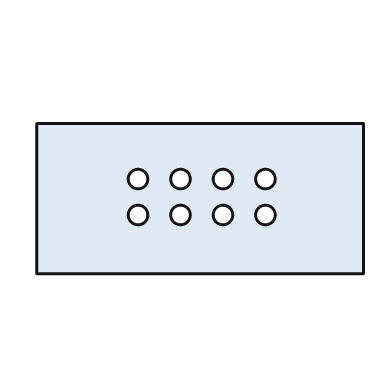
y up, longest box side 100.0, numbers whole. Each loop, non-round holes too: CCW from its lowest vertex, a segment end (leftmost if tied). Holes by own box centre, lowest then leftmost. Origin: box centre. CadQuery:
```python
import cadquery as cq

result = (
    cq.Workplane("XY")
    .moveTo(-50.0, -23.0)
    .lineTo(50.0, -23.0)
    .lineTo(50.0, 23.0)
    .lineTo(-50.0, 23.0)
    .close()
    .moveTo(-19.0, -5.0)
    .circle(3.0)
    .moveTo(-6.0, -5.0)
    .circle(3.0)
    .moveTo(7.0, -5.0)
    .circle(3.0)
    .moveTo(20.0, -5.0)
    .circle(3.0)
    .moveTo(-19.0, 6.0)
    .circle(3.0)
    .moveTo(-6.0, 6.0)
    .circle(3.0)
    .moveTo(7.0, 6.0)
    .circle(3.0)
    .moveTo(20.0, 6.0)
    .circle(3.0)
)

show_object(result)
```